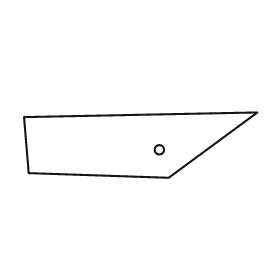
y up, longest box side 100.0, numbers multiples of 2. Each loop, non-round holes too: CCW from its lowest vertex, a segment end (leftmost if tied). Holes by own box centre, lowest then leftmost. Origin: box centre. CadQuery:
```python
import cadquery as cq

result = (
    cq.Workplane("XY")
    .moveTo(12.0, -14.0)
    .lineTo(50.0, 14.0)
    .lineTo(-50.0, 12.0)
    .lineTo(-48.0, -12.0)
    .close()
    .moveTo(8.0, -2.0)
    .circle(2.0)
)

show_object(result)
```